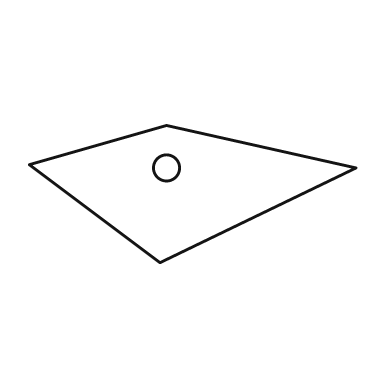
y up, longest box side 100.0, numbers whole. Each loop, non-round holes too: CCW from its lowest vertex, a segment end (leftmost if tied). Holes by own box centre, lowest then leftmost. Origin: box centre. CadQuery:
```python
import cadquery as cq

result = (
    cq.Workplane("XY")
    .moveTo(-10.0, -21.0)
    .lineTo(50.0, 8.0)
    .lineTo(-8.0, 21.0)
    .lineTo(-50.0, 9.0)
    .close()
    .moveTo(-8.0, 8.0)
    .circle(4.0)
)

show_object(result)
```